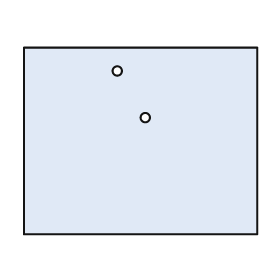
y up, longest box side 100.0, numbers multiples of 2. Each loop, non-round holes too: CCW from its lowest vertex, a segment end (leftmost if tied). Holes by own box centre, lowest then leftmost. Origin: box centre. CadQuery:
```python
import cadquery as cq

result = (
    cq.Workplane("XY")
    .moveTo(-50.0, -40.0)
    .lineTo(50.0, -40.0)
    .lineTo(50.0, 40.0)
    .lineTo(-50.0, 40.0)
    .close()
    .moveTo(2.0, 10.0)
    .circle(2.0)
    .moveTo(-10.0, 30.0)
    .circle(2.0)
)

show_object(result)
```